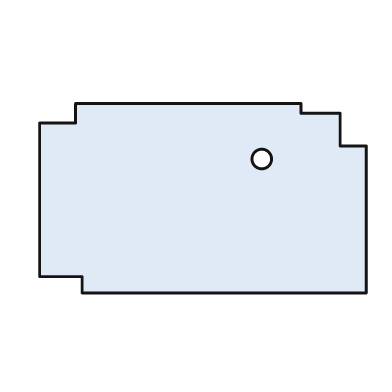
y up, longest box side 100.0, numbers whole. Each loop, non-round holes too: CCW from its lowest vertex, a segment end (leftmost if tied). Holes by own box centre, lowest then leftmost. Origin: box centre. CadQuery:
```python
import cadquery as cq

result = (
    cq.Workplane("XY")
    .moveTo(-37.0, -29.0)
    .lineTo(50.0, -29.0)
    .lineTo(50.0, 16.0)
    .lineTo(42.0, 16.0)
    .lineTo(42.0, 26.0)
    .lineTo(30.0, 26.0)
    .lineTo(30.0, 29.0)
    .lineTo(-39.0, 29.0)
    .lineTo(-39.0, 23.0)
    .lineTo(-50.0, 23.0)
    .lineTo(-50.0, -24.0)
    .lineTo(-37.0, -24.0)
    .close()
    .moveTo(18.0, 12.0)
    .circle(3.0)
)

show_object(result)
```